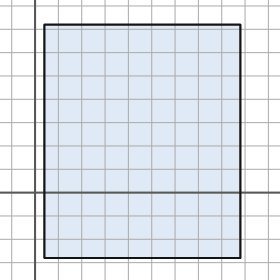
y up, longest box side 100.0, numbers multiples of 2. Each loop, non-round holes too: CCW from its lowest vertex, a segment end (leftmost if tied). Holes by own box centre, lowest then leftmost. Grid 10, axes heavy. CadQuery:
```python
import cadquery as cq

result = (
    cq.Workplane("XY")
    .moveTo(4.0, -28.0)
    .lineTo(88.0, -28.0)
    .lineTo(88.0, 72.0)
    .lineTo(4.0, 72.0)
    .close()
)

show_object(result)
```